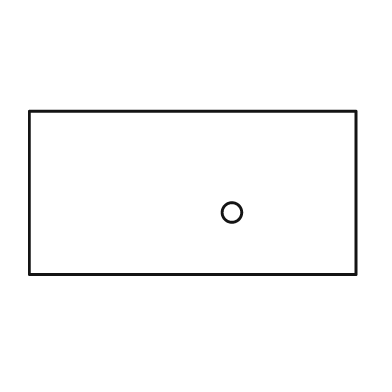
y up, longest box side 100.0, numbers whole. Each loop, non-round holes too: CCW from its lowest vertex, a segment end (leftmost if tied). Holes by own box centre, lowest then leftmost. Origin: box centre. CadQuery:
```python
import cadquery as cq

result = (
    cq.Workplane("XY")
    .moveTo(-50.0, -25.0)
    .lineTo(50.0, -25.0)
    .lineTo(50.0, 25.0)
    .lineTo(-50.0, 25.0)
    .close()
    .moveTo(12.0, -6.0)
    .circle(3.0)
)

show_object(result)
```